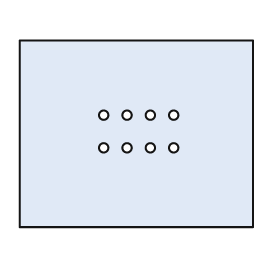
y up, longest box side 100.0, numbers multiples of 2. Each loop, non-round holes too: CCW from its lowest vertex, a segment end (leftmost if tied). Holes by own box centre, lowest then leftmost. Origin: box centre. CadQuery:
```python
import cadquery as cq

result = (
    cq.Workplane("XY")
    .moveTo(-50.0, -40.0)
    .lineTo(50.0, -40.0)
    .lineTo(50.0, 40.0)
    .lineTo(-50.0, 40.0)
    .close()
    .moveTo(-14.0, -6.0)
    .circle(2.0)
    .moveTo(-4.0, -6.0)
    .circle(2.0)
    .moveTo(6.0, -6.0)
    .circle(2.0)
    .moveTo(16.0, -6.0)
    .circle(2.0)
    .moveTo(-14.0, 8.0)
    .circle(2.0)
    .moveTo(-4.0, 8.0)
    .circle(2.0)
    .moveTo(6.0, 8.0)
    .circle(2.0)
    .moveTo(16.0, 8.0)
    .circle(2.0)
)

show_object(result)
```